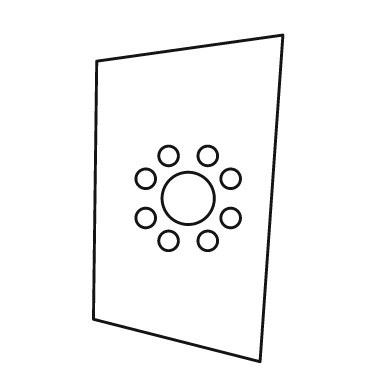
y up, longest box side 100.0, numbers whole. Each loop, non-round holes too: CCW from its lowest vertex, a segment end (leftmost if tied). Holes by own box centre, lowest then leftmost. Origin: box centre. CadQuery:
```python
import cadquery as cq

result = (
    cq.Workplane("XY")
    .moveTo(22.0, -50.0)
    .lineTo(29.0, 50.0)
    .lineTo(-28.0, 42.0)
    .lineTo(-29.0, -37.0)
    .close()
    .moveTo(-6.0, -13.0)
    .circle(3.0)
    .moveTo(6.0, -13.0)
    .circle(3.0)
    .moveTo(-13.0, -6.0)
    .circle(3.0)
    .moveTo(13.0, -6.0)
    .circle(3.0)
    .moveTo(0.0, 0.0)
    .circle(8.0)
    .moveTo(-13.0, 6.0)
    .circle(3.0)
    .moveTo(13.0, 6.0)
    .circle(3.0)
    .moveTo(-6.0, 13.0)
    .circle(3.0)
    .moveTo(6.0, 13.0)
    .circle(3.0)
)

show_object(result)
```